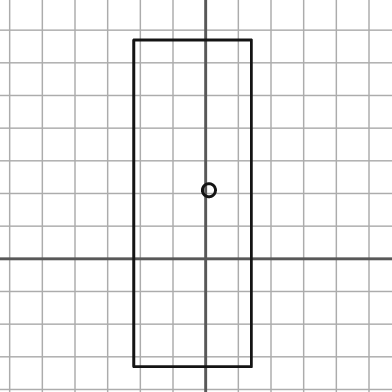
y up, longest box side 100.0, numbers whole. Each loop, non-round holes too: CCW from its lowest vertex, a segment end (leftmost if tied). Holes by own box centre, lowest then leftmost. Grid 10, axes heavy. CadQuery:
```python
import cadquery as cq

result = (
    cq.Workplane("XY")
    .moveTo(-22.0, -33.0)
    .lineTo(14.0, -33.0)
    .lineTo(14.0, 67.0)
    .lineTo(-22.0, 67.0)
    .close()
    .moveTo(1.0, 21.0)
    .circle(2.0)
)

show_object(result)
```